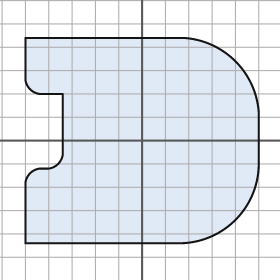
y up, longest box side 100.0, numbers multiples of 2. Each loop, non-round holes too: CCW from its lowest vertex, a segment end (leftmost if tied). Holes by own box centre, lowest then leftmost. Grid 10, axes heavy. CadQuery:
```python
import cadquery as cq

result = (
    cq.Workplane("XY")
    .moveTo(-50.0, -44.0)
    .lineTo(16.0, -44.0)
    .threePointArc((40.0, -34.0), (50.0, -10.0))
    .lineTo(50.0, 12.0)
    .threePointArc((40.0, 34.0), (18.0, 44.0))
    .lineTo(-50.0, 44.0)
    .lineTo(-50.0, 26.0)
    .threePointArc((-48.0, 22.0), (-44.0, 20.0))
    .lineTo(-34.0, 20.0)
    .lineTo(-34.0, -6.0)
    .threePointArc((-36.0, -10.0), (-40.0, -12.0))
    .lineTo(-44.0, -12.0)
    .threePointArc((-48.0, -14.0), (-50.0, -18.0))
    .close()
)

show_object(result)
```